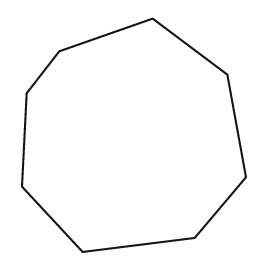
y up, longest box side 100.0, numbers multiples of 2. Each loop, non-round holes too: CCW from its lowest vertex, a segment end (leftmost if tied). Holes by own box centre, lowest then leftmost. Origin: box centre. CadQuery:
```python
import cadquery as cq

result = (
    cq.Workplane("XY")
    .moveTo(-22.0, -50.0)
    .lineTo(26.0, -44.0)
    .lineTo(48.0, -18.0)
    .lineTo(40.0, 26.0)
    .lineTo(8.0, 50.0)
    .lineTo(-32.0, 36.0)
    .lineTo(-46.0, 18.0)
    .lineTo(-48.0, -22.0)
    .close()
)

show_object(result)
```